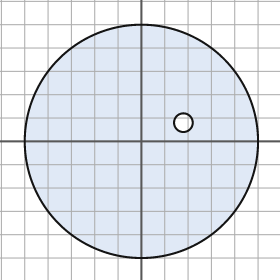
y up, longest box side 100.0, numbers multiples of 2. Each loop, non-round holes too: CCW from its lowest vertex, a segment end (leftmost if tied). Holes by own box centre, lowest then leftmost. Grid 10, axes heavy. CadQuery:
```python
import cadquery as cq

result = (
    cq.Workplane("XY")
    .moveTo(0.0, 0.0)
    .circle(50.0)
    .moveTo(18.0, 8.0)
    .circle(4.0)
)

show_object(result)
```